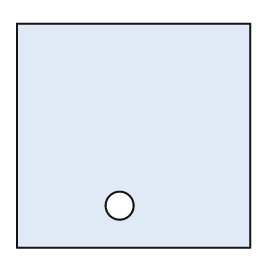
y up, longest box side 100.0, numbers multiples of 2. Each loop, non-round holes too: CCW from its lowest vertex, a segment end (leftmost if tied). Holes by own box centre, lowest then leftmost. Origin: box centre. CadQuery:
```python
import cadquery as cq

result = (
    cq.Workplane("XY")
    .moveTo(-50.0, -48.0)
    .lineTo(50.0, -48.0)
    .lineTo(50.0, 48.0)
    .lineTo(-50.0, 48.0)
    .close()
    .moveTo(-6.0, -30.0)
    .circle(6.0)
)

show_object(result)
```